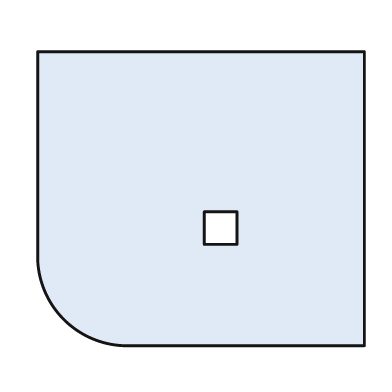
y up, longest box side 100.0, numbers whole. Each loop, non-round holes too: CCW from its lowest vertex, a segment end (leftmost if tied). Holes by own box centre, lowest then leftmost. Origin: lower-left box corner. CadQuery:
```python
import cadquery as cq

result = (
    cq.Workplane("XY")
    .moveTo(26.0, 0.0)
    .lineTo(100.0, 0.0)
    .lineTo(100.0, 90.0)
    .lineTo(0.0, 90.0)
    .lineTo(0.0, 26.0)
    .threePointArc((8.0, 8.0), (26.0, 0.0))
    .close()
    .moveTo(51.0, 31.0)
    .lineTo(61.0, 31.0)
    .lineTo(61.0, 41.0)
    .lineTo(51.0, 41.0)
    .close()
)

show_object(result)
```